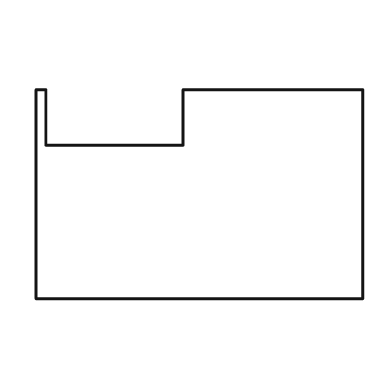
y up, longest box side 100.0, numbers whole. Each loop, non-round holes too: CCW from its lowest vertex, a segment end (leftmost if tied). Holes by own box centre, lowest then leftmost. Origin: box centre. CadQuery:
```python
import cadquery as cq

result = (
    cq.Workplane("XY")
    .moveTo(-50.0, -32.0)
    .lineTo(50.0, -32.0)
    .lineTo(50.0, 32.0)
    .lineTo(-5.0, 32.0)
    .lineTo(-5.0, 15.0)
    .lineTo(-47.0, 15.0)
    .lineTo(-47.0, 32.0)
    .lineTo(-50.0, 32.0)
    .close()
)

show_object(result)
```